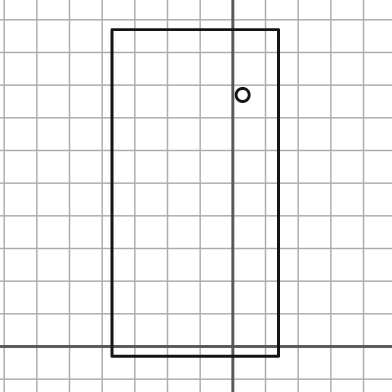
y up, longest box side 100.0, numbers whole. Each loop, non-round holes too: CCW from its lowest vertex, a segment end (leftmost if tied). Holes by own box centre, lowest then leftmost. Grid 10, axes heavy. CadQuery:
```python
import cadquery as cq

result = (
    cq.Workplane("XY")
    .moveTo(-37.0, -3.0)
    .lineTo(14.0, -3.0)
    .lineTo(14.0, 97.0)
    .lineTo(-37.0, 97.0)
    .close()
    .moveTo(3.0, 77.0)
    .circle(2.0)
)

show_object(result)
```